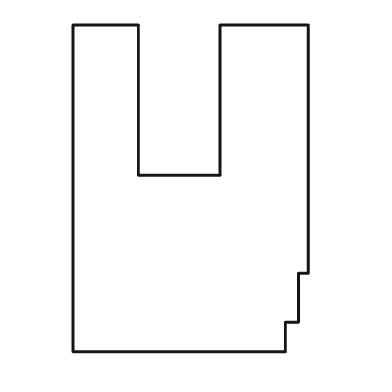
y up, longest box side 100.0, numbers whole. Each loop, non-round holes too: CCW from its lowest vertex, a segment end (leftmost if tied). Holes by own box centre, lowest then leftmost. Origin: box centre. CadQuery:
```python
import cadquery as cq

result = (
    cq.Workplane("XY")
    .moveTo(-36.0, -50.0)
    .lineTo(29.0, -50.0)
    .lineTo(29.0, -41.0)
    .lineTo(33.0, -41.0)
    .lineTo(33.0, -26.0)
    .lineTo(36.0, -26.0)
    .lineTo(36.0, 50.0)
    .lineTo(9.0, 50.0)
    .lineTo(9.0, 4.0)
    .lineTo(-16.0, 4.0)
    .lineTo(-16.0, 50.0)
    .lineTo(-36.0, 50.0)
    .close()
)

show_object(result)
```